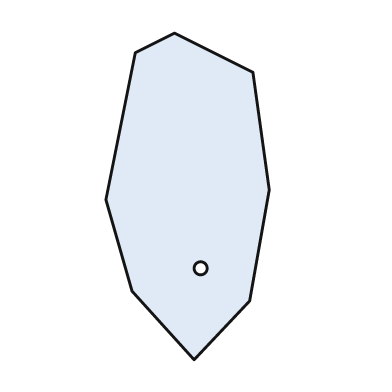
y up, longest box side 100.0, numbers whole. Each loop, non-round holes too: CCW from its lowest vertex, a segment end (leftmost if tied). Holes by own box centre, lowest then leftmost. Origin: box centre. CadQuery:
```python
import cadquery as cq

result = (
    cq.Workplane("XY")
    .moveTo(2.0, -50.0)
    .lineTo(19.0, -32.0)
    .lineTo(25.0, 2.0)
    .lineTo(20.0, 38.0)
    .lineTo(-4.0, 50.0)
    .lineTo(-16.0, 44.0)
    .lineTo(-25.0, -1.0)
    .lineTo(-17.0, -29.0)
    .close()
    .moveTo(4.0, -22.0)
    .circle(2.0)
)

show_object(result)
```